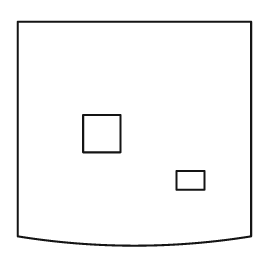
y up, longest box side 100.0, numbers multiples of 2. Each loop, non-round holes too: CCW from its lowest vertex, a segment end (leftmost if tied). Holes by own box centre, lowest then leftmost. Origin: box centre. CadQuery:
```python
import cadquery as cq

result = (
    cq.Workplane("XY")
    .moveTo(-50.0, -44.0)
    .threePointArc((0.0, -48.0), (50.0, -44.0))
    .lineTo(50.0, 48.0)
    .lineTo(-50.0, 48.0)
    .close()
    .moveTo(18.0, -24.0)
    .lineTo(30.0, -24.0)
    .lineTo(30.0, -16.0)
    .lineTo(18.0, -16.0)
    .close()
    .moveTo(-22.0, -8.0)
    .lineTo(-6.0, -8.0)
    .lineTo(-6.0, 8.0)
    .lineTo(-22.0, 8.0)
    .close()
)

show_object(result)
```